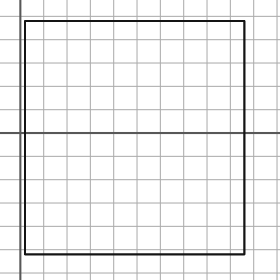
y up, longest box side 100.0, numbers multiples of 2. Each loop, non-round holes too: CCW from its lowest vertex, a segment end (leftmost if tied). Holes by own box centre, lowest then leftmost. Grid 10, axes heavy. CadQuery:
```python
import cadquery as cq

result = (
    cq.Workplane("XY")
    .moveTo(2.0, -52.0)
    .lineTo(96.0, -52.0)
    .lineTo(96.0, 48.0)
    .lineTo(2.0, 48.0)
    .close()
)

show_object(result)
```